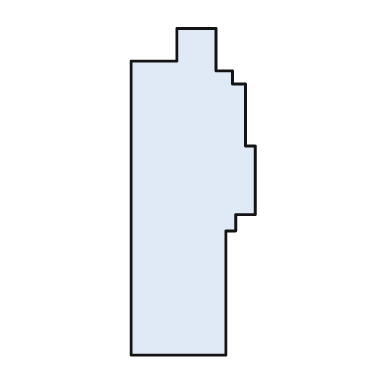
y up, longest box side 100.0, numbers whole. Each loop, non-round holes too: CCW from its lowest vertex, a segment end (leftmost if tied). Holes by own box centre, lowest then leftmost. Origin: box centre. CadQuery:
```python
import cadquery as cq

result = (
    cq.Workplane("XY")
    .moveTo(-19.0, -50.0)
    .lineTo(10.0, -50.0)
    .lineTo(10.0, -12.0)
    .lineTo(13.0, -12.0)
    .lineTo(13.0, -7.0)
    .lineTo(19.0, -7.0)
    .lineTo(19.0, 14.0)
    .lineTo(16.0, 14.0)
    .lineTo(16.0, 33.0)
    .lineTo(12.0, 33.0)
    .lineTo(12.0, 37.0)
    .lineTo(7.0, 37.0)
    .lineTo(7.0, 50.0)
    .lineTo(-5.0, 50.0)
    .lineTo(-5.0, 40.0)
    .lineTo(-19.0, 40.0)
    .close()
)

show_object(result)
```